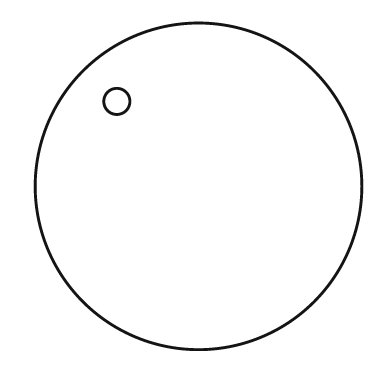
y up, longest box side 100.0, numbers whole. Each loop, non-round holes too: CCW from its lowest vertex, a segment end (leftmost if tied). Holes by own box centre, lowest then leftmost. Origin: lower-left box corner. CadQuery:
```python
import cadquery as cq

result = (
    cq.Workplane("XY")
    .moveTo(50.0, 50.0)
    .circle(50.0)
    .moveTo(25.0, 76.0)
    .circle(4.0)
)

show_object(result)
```